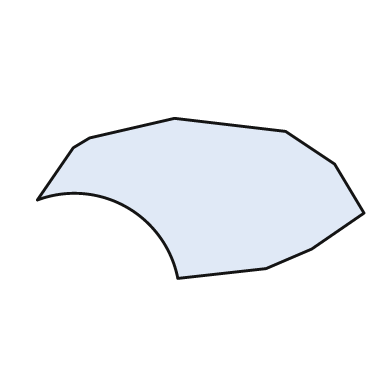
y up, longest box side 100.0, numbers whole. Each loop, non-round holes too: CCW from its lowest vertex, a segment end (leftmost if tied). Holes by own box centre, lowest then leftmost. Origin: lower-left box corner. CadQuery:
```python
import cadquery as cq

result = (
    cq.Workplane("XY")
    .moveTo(43.0, 0.0)
    .lineTo(70.0, 3.0)
    .lineTo(84.0, 9.0)
    .lineTo(100.0, 20.0)
    .lineTo(91.0, 35.0)
    .lineTo(76.0, 45.0)
    .lineTo(42.0, 49.0)
    .lineTo(16.0, 43.0)
    .lineTo(11.0, 40.0)
    .lineTo(0.0, 24.0)
    .threePointArc((27.0, 22.0), (43.0, 0.0))
    .close()
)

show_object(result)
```